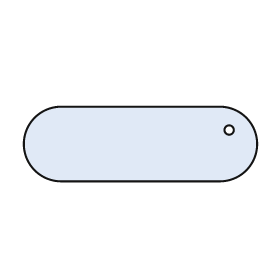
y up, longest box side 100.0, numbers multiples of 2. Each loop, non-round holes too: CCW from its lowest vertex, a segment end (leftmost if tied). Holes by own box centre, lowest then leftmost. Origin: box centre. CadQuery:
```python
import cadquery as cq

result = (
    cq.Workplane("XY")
    .moveTo(-34.0, -16.0)
    .lineTo(34.0, -16.0)
    .threePointArc((50.0, 0.0), (34.0, 16.0))
    .lineTo(-34.0, 16.0)
    .threePointArc((-50.0, 0.0), (-34.0, -16.0))
    .close()
    .moveTo(38.0, 6.0)
    .circle(2.0)
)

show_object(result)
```